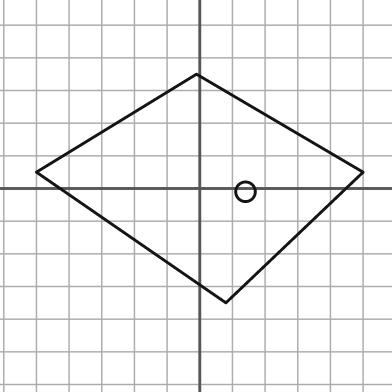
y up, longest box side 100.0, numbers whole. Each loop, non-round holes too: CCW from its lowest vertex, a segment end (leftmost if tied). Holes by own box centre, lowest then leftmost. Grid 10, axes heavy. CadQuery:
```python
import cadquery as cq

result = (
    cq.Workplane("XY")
    .moveTo(8.0, -35.0)
    .lineTo(50.0, 5.0)
    .lineTo(-1.0, 35.0)
    .lineTo(-50.0, 5.0)
    .close()
    .moveTo(14.0, -1.0)
    .circle(3.0)
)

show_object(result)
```